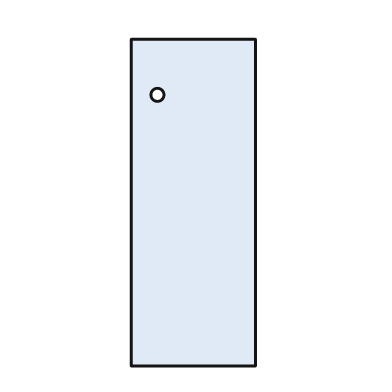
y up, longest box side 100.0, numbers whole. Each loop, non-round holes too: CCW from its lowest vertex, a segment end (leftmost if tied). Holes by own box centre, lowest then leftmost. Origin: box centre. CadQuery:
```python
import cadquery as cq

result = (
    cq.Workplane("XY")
    .moveTo(-19.0, -50.0)
    .lineTo(19.0, -50.0)
    .lineTo(19.0, 50.0)
    .lineTo(-19.0, 50.0)
    .close()
    .moveTo(-11.0, 33.0)
    .circle(2.0)
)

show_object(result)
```